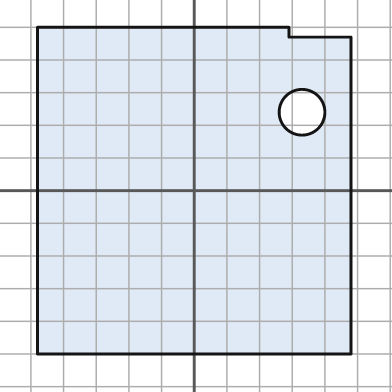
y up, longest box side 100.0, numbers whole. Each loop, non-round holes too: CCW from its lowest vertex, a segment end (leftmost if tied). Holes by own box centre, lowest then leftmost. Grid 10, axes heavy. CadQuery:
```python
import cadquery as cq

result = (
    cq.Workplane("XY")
    .moveTo(-48.0, -50.0)
    .lineTo(48.0, -50.0)
    .lineTo(48.0, 47.0)
    .lineTo(29.0, 47.0)
    .lineTo(29.0, 50.0)
    .lineTo(-48.0, 50.0)
    .close()
    .moveTo(33.0, 24.0)
    .circle(7.0)
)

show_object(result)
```